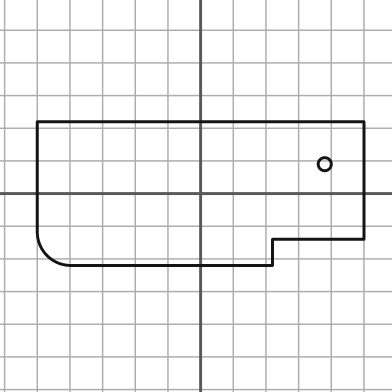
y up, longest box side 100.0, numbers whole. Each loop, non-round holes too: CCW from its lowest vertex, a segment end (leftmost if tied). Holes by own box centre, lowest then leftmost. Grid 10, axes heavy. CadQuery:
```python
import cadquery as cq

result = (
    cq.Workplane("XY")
    .moveTo(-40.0, -22.0)
    .lineTo(22.0, -22.0)
    .lineTo(22.0, -14.0)
    .lineTo(50.0, -14.0)
    .lineTo(50.0, 22.0)
    .lineTo(-50.0, 22.0)
    .lineTo(-50.0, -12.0)
    .threePointArc((-47.0, -19.0), (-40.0, -22.0))
    .close()
    .moveTo(38.0, 9.0)
    .circle(2.0)
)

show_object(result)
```